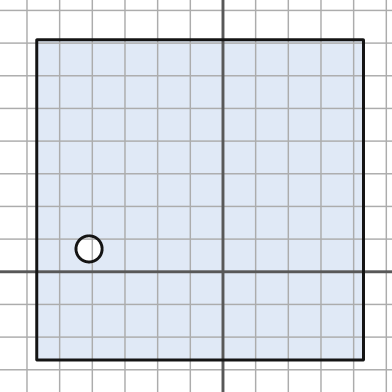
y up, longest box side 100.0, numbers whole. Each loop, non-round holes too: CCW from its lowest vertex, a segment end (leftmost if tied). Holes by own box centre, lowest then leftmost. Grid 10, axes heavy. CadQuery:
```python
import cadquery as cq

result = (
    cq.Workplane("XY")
    .moveTo(-57.0, -27.0)
    .lineTo(43.0, -27.0)
    .lineTo(43.0, 71.0)
    .lineTo(-57.0, 71.0)
    .close()
    .moveTo(-41.0, 7.0)
    .circle(4.0)
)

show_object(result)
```